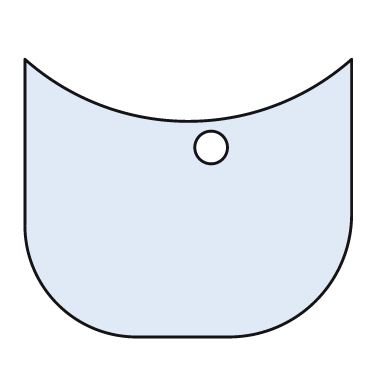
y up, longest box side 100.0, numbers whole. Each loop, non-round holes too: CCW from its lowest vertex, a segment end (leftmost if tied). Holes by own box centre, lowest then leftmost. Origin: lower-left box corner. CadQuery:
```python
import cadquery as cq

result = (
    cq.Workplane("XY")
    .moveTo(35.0, 0.0)
    .lineTo(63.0, 0.0)
    .threePointArc((89.0, 11.0), (100.0, 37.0))
    .lineTo(100.0, 85.0)
    .threePointArc((50.0, 66.0), (0.0, 85.0))
    .lineTo(0.0, 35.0)
    .threePointArc((10.0, 10.0), (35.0, 0.0))
    .close()
    .moveTo(57.0, 58.0)
    .circle(5.0)
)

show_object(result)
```